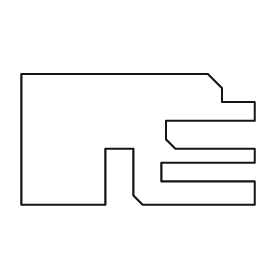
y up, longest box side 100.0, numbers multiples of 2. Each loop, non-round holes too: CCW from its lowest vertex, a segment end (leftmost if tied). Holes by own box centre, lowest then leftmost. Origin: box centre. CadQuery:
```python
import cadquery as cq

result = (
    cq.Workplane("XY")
    .moveTo(-50.0, -28.0)
    .lineTo(-14.0, -28.0)
    .lineTo(-14.0, -4.0)
    .lineTo(-2.0, -4.0)
    .lineTo(-2.0, -24.0)
    .lineTo(2.0, -28.0)
    .lineTo(50.0, -28.0)
    .lineTo(50.0, -18.0)
    .lineTo(10.0, -18.0)
    .lineTo(10.0, -10.0)
    .lineTo(50.0, -10.0)
    .lineTo(50.0, -4.0)
    .lineTo(16.0, -4.0)
    .lineTo(12.0, 0.0)
    .lineTo(12.0, 8.0)
    .lineTo(50.0, 8.0)
    .lineTo(50.0, 16.0)
    .lineTo(36.0, 16.0)
    .lineTo(36.0, 22.0)
    .lineTo(30.0, 28.0)
    .lineTo(-50.0, 28.0)
    .close()
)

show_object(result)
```